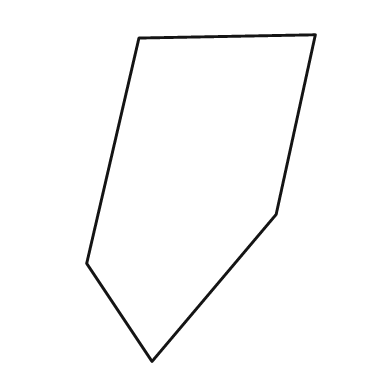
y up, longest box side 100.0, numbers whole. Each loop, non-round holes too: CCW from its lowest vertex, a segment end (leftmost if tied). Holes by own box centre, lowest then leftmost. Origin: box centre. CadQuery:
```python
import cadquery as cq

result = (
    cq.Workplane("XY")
    .moveTo(-15.0, -50.0)
    .lineTo(23.0, -5.0)
    .lineTo(35.0, 50.0)
    .lineTo(-19.0, 49.0)
    .lineTo(-35.0, -20.0)
    .close()
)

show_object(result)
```